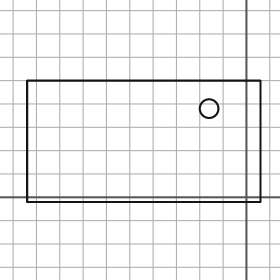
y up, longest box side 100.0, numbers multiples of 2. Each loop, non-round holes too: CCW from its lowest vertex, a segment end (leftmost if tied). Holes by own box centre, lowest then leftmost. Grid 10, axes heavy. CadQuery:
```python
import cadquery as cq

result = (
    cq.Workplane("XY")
    .moveTo(-94.0, -2.0)
    .lineTo(6.0, -2.0)
    .lineTo(6.0, 50.0)
    .lineTo(-94.0, 50.0)
    .close()
    .moveTo(-16.0, 38.0)
    .circle(4.0)
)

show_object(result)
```